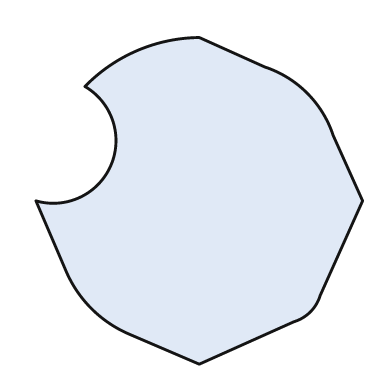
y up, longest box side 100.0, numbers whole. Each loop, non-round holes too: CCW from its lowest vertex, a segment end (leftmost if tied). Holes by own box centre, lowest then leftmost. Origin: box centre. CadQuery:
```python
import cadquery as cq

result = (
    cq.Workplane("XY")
    .moveTo(0.0, -50.0)
    .lineTo(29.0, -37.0)
    .threePointArc((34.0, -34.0), (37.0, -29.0))
    .lineTo(50.0, 0.0)
    .lineTo(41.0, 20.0)
    .threePointArc((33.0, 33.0), (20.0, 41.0))
    .lineTo(0.0, 50.0)
    .threePointArc((-19.0, 46.0), (-35.0, 35.0))
    .threePointArc((-27.0, 11.0), (-50.0, 0.0))
    .lineTo(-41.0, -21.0)
    .threePointArc((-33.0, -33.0), (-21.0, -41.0))
    .close()
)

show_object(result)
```